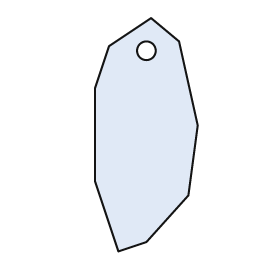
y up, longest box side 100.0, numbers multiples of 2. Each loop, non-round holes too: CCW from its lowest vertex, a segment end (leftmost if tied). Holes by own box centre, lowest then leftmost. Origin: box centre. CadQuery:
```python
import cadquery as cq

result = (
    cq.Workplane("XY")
    .moveTo(-12.0, -50.0)
    .lineTo(0.0, -46.0)
    .lineTo(18.0, -26.0)
    .lineTo(22.0, 4.0)
    .lineTo(14.0, 40.0)
    .lineTo(2.0, 50.0)
    .lineTo(-16.0, 38.0)
    .lineTo(-22.0, 20.0)
    .lineTo(-22.0, -20.0)
    .close()
    .moveTo(0.0, 36.0)
    .circle(4.0)
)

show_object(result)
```